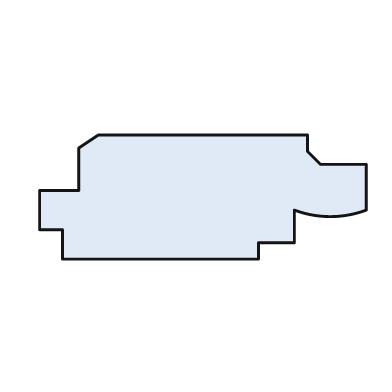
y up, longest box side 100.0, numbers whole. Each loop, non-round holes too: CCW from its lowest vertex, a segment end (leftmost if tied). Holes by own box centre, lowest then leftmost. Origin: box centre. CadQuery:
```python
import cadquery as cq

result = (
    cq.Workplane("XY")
    .moveTo(-43.0, -19.0)
    .lineTo(17.0, -19.0)
    .lineTo(17.0, -14.0)
    .lineTo(28.0, -14.0)
    .lineTo(28.0, -4.0)
    .threePointArc((39.0, -6.0), (50.0, -4.0))
    .lineTo(50.0, 10.0)
    .lineTo(36.0, 10.0)
    .lineTo(32.0, 14.0)
    .lineTo(32.0, 19.0)
    .lineTo(-32.0, 19.0)
    .lineTo(-38.0, 15.0)
    .lineTo(-38.0, 2.0)
    .lineTo(-50.0, 2.0)
    .lineTo(-50.0, -10.0)
    .lineTo(-43.0, -10.0)
    .close()
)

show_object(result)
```